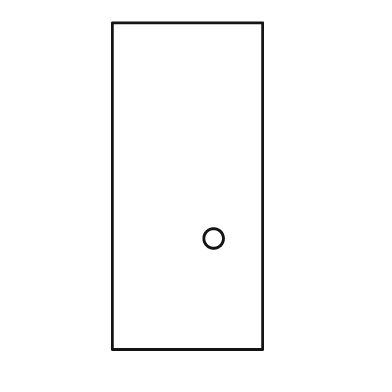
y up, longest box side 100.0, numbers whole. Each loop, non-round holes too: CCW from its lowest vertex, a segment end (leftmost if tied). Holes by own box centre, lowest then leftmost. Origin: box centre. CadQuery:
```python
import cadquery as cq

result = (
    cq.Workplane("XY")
    .moveTo(-23.0, -50.0)
    .lineTo(23.0, -50.0)
    .lineTo(23.0, 50.0)
    .lineTo(-23.0, 50.0)
    .close()
    .moveTo(8.0, -16.0)
    .circle(3.0)
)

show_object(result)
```